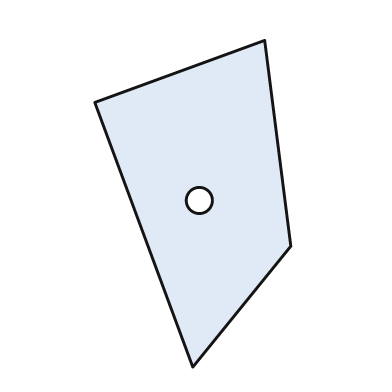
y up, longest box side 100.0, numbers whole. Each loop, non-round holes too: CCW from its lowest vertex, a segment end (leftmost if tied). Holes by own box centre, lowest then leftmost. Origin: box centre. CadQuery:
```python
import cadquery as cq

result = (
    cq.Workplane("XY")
    .moveTo(0.0, -50.0)
    .lineTo(30.0, -13.0)
    .lineTo(22.0, 50.0)
    .lineTo(-30.0, 31.0)
    .close()
    .moveTo(2.0, 1.0)
    .circle(4.0)
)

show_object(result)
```